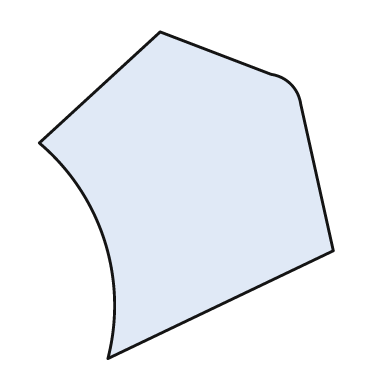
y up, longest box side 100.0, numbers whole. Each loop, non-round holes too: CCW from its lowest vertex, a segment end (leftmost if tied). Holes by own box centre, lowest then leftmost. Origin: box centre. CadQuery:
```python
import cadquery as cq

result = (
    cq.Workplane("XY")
    .moveTo(-24.0, -50.0)
    .lineTo(45.0, -17.0)
    .lineTo(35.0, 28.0)
    .threePointArc((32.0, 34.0), (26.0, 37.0))
    .lineTo(-8.0, 50.0)
    .lineTo(-45.0, 16.0)
    .threePointArc((-25.0, -14.0), (-24.0, -50.0))
    .close()
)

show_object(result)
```